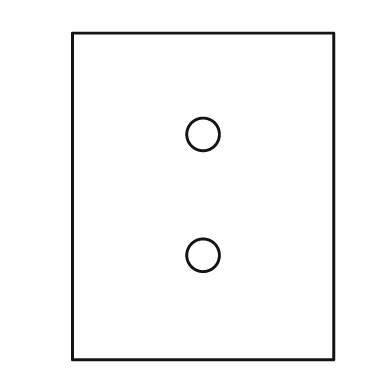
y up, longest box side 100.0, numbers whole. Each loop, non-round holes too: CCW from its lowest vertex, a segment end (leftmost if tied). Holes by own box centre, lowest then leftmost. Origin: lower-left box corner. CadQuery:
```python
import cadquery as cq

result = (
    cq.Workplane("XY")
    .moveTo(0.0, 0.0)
    .lineTo(80.0, 0.0)
    .lineTo(80.0, 100.0)
    .lineTo(0.0, 100.0)
    .close()
    .moveTo(40.0, 32.0)
    .circle(5.0)
    .moveTo(40.0, 69.0)
    .circle(5.0)
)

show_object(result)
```